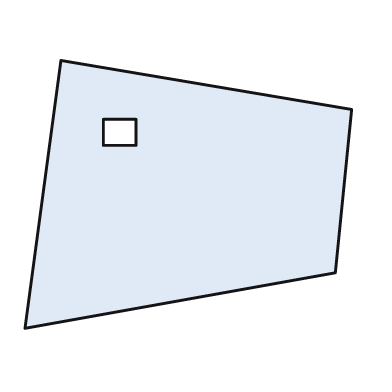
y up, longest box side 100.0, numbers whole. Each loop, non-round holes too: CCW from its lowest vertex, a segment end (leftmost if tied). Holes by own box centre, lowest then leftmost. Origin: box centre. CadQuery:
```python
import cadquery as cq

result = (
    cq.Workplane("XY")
    .moveTo(-50.0, -41.0)
    .lineTo(45.0, -24.0)
    .lineTo(50.0, 26.0)
    .lineTo(-39.0, 41.0)
    .close()
    .moveTo(-26.0, 15.0)
    .lineTo(-16.0, 15.0)
    .lineTo(-16.0, 23.0)
    .lineTo(-26.0, 23.0)
    .close()
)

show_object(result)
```